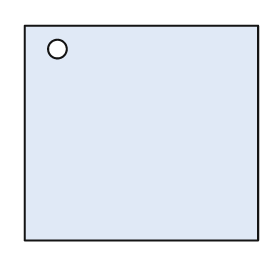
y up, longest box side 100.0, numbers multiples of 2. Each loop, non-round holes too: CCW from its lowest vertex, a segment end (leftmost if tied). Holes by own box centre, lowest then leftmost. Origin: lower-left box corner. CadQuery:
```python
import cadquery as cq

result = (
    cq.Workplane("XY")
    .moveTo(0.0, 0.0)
    .lineTo(100.0, 0.0)
    .lineTo(100.0, 92.0)
    .lineTo(0.0, 92.0)
    .close()
    .moveTo(14.0, 82.0)
    .circle(4.0)
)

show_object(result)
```